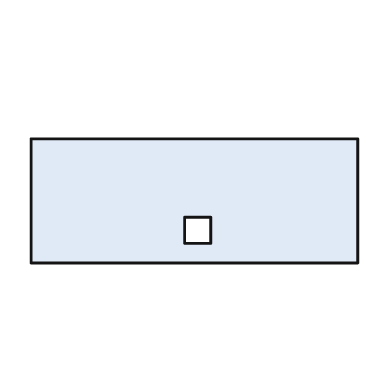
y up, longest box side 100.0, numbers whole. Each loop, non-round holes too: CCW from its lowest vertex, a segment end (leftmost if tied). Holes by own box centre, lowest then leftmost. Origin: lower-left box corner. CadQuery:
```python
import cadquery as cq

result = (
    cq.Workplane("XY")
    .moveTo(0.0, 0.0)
    .lineTo(100.0, 0.0)
    .lineTo(100.0, 38.0)
    .lineTo(0.0, 38.0)
    .close()
    .moveTo(47.0, 6.0)
    .lineTo(55.0, 6.0)
    .lineTo(55.0, 14.0)
    .lineTo(47.0, 14.0)
    .close()
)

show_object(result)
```